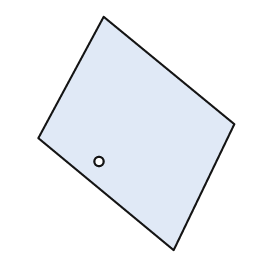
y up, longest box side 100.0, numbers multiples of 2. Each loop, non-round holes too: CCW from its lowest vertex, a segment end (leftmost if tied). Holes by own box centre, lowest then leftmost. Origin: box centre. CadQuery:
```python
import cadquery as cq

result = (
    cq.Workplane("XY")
    .moveTo(16.0, -50.0)
    .lineTo(42.0, 4.0)
    .lineTo(-14.0, 50.0)
    .lineTo(-42.0, -2.0)
    .close()
    .moveTo(-16.0, -12.0)
    .circle(2.0)
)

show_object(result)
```